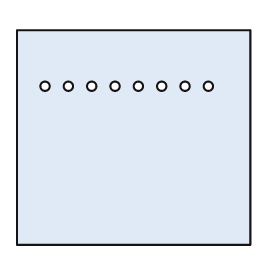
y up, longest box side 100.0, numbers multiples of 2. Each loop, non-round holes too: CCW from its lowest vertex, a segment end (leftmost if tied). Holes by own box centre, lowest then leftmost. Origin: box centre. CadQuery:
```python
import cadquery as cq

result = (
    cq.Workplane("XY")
    .moveTo(-50.0, -46.0)
    .lineTo(50.0, -46.0)
    .lineTo(50.0, 46.0)
    .lineTo(-50.0, 46.0)
    .close()
    .moveTo(-38.0, 22.0)
    .circle(2.0)
    .moveTo(-28.0, 22.0)
    .circle(2.0)
    .moveTo(-18.0, 22.0)
    .circle(2.0)
    .moveTo(-8.0, 22.0)
    .circle(2.0)
    .moveTo(2.0, 22.0)
    .circle(2.0)
    .moveTo(12.0, 22.0)
    .circle(2.0)
    .moveTo(22.0, 22.0)
    .circle(2.0)
    .moveTo(32.0, 22.0)
    .circle(2.0)
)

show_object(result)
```